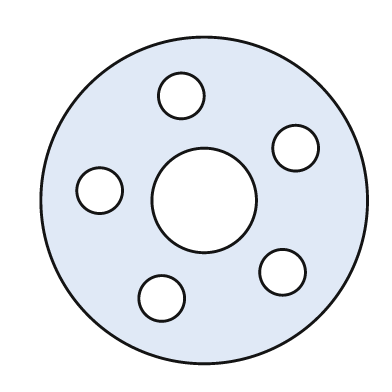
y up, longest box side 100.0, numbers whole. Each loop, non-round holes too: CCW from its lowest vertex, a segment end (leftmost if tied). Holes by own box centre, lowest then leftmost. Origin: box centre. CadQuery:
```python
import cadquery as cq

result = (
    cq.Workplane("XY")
    .moveTo(0.0, 0.0)
    .circle(50.0)
    .moveTo(-13.0, -30.0)
    .circle(7.0)
    .moveTo(24.0, -22.0)
    .circle(7.0)
    .moveTo(0.0, 0.0)
    .circle(16.0)
    .moveTo(-32.0, 3.0)
    .circle(7.0)
    .moveTo(28.0, 16.0)
    .circle(7.0)
    .moveTo(-7.0, 32.0)
    .circle(7.0)
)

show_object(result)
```